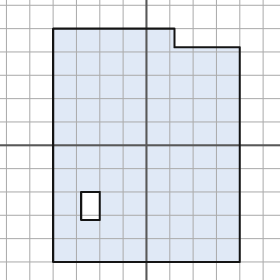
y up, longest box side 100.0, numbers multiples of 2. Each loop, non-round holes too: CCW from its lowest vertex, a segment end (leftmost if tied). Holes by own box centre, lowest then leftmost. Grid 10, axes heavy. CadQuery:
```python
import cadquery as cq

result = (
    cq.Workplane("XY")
    .moveTo(-40.0, -50.0)
    .lineTo(40.0, -50.0)
    .lineTo(40.0, 42.0)
    .lineTo(12.0, 42.0)
    .lineTo(12.0, 50.0)
    .lineTo(-40.0, 50.0)
    .close()
    .moveTo(-28.0, -32.0)
    .lineTo(-20.0, -32.0)
    .lineTo(-20.0, -20.0)
    .lineTo(-28.0, -20.0)
    .close()
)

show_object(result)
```